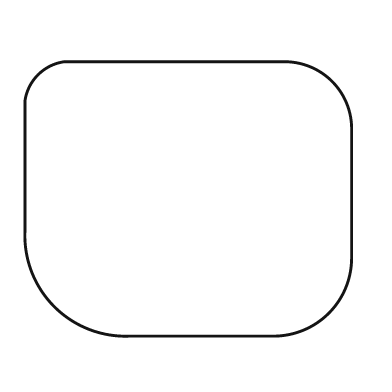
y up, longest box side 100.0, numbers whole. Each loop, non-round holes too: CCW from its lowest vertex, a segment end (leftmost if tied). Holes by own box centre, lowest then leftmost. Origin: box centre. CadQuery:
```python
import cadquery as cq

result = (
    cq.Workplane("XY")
    .moveTo(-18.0, -42.0)
    .lineTo(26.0, -42.0)
    .threePointArc((43.0, -35.0), (50.0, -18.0))
    .lineTo(50.0, 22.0)
    .threePointArc((44.0, 36.0), (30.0, 42.0))
    .lineTo(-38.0, 42.0)
    .threePointArc((-46.0, 38.0), (-50.0, 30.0))
    .lineTo(-50.0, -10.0)
    .threePointArc((-41.0, -33.0), (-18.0, -42.0))
    .close()
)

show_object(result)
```